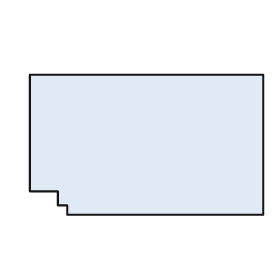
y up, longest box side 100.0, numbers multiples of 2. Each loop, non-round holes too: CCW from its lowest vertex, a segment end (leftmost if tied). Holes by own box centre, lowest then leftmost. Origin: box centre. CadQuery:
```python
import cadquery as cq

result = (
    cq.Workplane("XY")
    .moveTo(-34.0, -30.0)
    .lineTo(50.0, -30.0)
    .lineTo(50.0, 30.0)
    .lineTo(-50.0, 30.0)
    .lineTo(-50.0, -20.0)
    .lineTo(-38.0, -20.0)
    .lineTo(-38.0, -26.0)
    .lineTo(-34.0, -26.0)
    .close()
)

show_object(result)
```